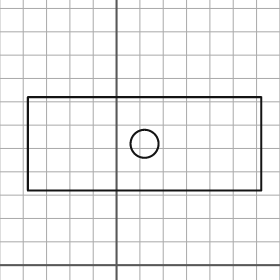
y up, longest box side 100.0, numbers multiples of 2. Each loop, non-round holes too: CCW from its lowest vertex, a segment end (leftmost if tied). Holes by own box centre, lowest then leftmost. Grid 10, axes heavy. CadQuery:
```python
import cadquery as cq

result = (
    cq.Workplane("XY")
    .moveTo(-38.0, 32.0)
    .lineTo(62.0, 32.0)
    .lineTo(62.0, 72.0)
    .lineTo(-38.0, 72.0)
    .close()
    .moveTo(12.0, 52.0)
    .circle(6.0)
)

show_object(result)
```